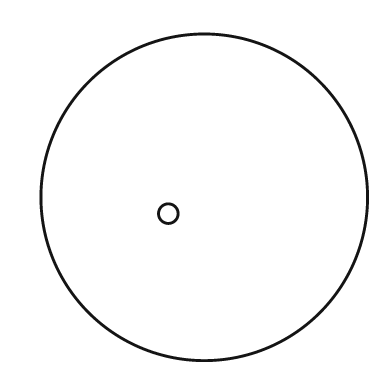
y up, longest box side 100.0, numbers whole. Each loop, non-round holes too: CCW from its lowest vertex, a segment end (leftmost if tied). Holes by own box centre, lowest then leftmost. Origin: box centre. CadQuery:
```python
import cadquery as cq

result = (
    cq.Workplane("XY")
    .moveTo(0.0, 0.0)
    .circle(50.0)
    .moveTo(-11.0, -5.0)
    .circle(3.0)
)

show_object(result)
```